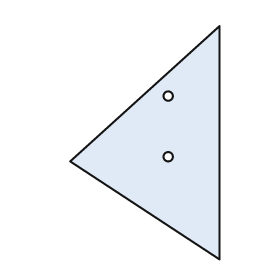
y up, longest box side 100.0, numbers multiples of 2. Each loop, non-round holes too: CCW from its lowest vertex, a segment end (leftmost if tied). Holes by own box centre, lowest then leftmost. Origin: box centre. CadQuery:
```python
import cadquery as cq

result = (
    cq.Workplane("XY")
    .moveTo(32.0, -50.0)
    .lineTo(32.0, 50.0)
    .lineTo(-32.0, -8.0)
    .close()
    .moveTo(10.0, -6.0)
    .circle(2.0)
    .moveTo(10.0, 20.0)
    .circle(2.0)
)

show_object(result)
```